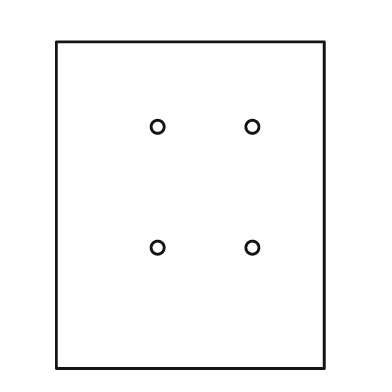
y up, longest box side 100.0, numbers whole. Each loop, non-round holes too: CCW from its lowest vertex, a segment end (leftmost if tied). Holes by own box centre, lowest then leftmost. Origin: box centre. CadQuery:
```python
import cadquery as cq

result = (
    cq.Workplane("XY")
    .moveTo(-41.0, -50.0)
    .lineTo(41.0, -50.0)
    .lineTo(41.0, 50.0)
    .lineTo(-41.0, 50.0)
    .close()
    .moveTo(-10.0, -13.0)
    .circle(2.0)
    .moveTo(19.0, -13.0)
    .circle(2.0)
    .moveTo(-10.0, 24.0)
    .circle(2.0)
    .moveTo(19.0, 24.0)
    .circle(2.0)
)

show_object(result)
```